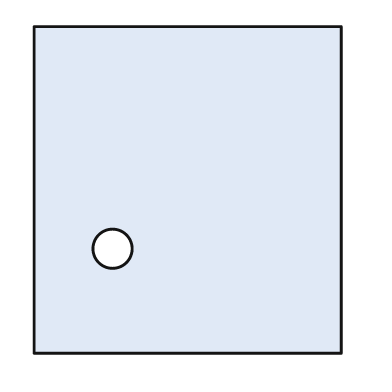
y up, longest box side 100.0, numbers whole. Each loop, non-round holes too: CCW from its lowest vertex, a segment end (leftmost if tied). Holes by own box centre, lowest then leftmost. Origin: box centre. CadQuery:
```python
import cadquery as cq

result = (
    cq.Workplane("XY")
    .moveTo(-47.0, -50.0)
    .lineTo(47.0, -50.0)
    .lineTo(47.0, 50.0)
    .lineTo(-47.0, 50.0)
    .close()
    .moveTo(-23.0, -18.0)
    .circle(6.0)
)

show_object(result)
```